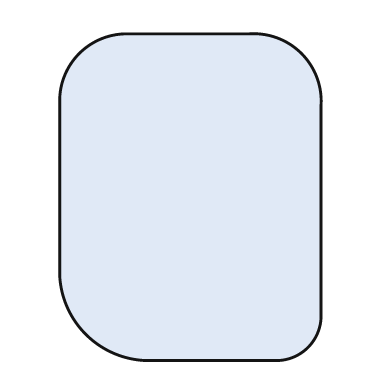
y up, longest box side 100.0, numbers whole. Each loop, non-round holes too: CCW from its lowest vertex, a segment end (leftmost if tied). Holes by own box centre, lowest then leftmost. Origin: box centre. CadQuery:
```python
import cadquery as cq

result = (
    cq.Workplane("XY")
    .moveTo(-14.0, -50.0)
    .lineTo(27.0, -50.0)
    .threePointArc((36.0, -46.0), (40.0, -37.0))
    .lineTo(40.0, 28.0)
    .threePointArc((34.0, 44.0), (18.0, 50.0))
    .lineTo(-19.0, 50.0)
    .threePointArc((-34.0, 44.0), (-40.0, 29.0))
    .lineTo(-40.0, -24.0)
    .threePointArc((-32.0, -42.0), (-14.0, -50.0))
    .close()
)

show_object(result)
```